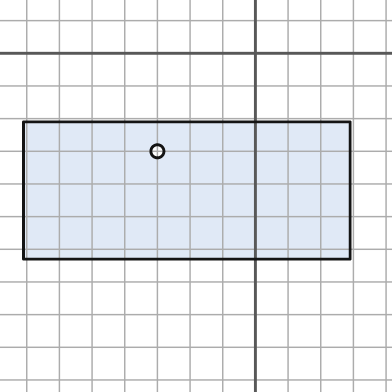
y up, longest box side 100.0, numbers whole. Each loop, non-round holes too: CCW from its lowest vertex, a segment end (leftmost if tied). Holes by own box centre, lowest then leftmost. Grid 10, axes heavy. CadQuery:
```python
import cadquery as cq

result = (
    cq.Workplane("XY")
    .moveTo(-71.0, -63.0)
    .lineTo(29.0, -63.0)
    .lineTo(29.0, -21.0)
    .lineTo(-71.0, -21.0)
    .close()
    .moveTo(-30.0, -30.0)
    .circle(2.0)
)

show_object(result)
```